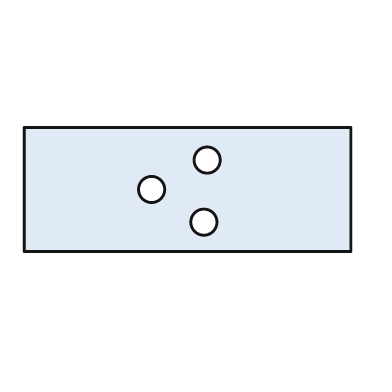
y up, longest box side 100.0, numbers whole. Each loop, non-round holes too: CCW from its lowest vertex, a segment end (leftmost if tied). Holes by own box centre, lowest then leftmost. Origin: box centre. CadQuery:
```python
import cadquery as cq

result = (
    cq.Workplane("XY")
    .moveTo(-50.0, -19.0)
    .lineTo(50.0, -19.0)
    .lineTo(50.0, 19.0)
    .lineTo(-50.0, 19.0)
    .close()
    .moveTo(5.0, -10.0)
    .circle(4.0)
    .moveTo(-11.0, 0.0)
    .circle(4.0)
    .moveTo(6.0, 9.0)
    .circle(4.0)
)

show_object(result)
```